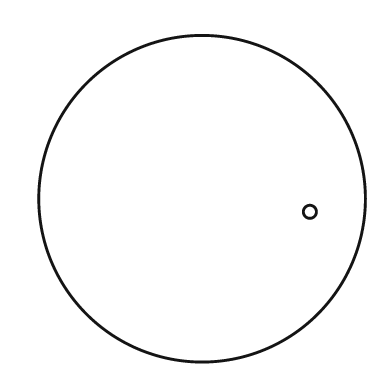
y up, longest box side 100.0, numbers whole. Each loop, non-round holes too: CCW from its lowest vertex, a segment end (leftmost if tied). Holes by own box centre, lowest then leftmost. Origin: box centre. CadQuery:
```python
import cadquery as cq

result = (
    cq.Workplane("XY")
    .moveTo(0.0, 0.0)
    .circle(50.0)
    .moveTo(33.0, -4.0)
    .circle(2.0)
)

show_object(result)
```